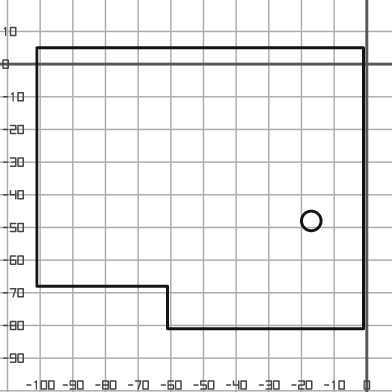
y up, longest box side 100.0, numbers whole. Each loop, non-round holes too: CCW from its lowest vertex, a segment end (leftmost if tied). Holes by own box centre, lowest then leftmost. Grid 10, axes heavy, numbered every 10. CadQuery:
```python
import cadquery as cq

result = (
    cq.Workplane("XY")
    .moveTo(-61.0, -81.0)
    .lineTo(-1.0, -81.0)
    .lineTo(-1.0, 5.0)
    .lineTo(-101.0, 5.0)
    .lineTo(-101.0, -68.0)
    .lineTo(-61.0, -68.0)
    .close()
    .moveTo(-17.0, -48.0)
    .circle(3.0)
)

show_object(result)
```